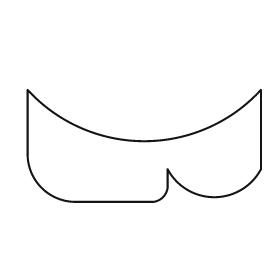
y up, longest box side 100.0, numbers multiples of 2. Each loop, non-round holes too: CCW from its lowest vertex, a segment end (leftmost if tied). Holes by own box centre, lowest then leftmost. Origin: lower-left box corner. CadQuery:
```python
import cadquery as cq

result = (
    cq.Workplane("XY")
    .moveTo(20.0, 0.0)
    .lineTo(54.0, 0.0)
    .threePointArc((58.0, 2.0), (60.0, 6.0))
    .lineTo(60.0, 14.0)
    .threePointArc((80.0, 2.0), (100.0, 14.0))
    .lineTo(100.0, 48.0)
    .threePointArc((50.0, 26.0), (0.0, 48.0))
    .lineTo(0.0, 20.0)
    .threePointArc((6.0, 6.0), (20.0, 0.0))
    .close()
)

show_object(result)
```